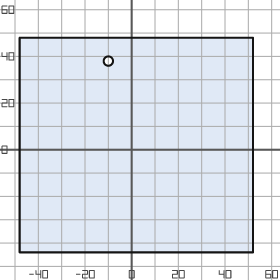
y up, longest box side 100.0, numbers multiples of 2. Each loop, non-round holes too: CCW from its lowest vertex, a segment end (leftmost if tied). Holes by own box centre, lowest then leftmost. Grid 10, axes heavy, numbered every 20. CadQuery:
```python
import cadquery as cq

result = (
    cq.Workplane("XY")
    .moveTo(-48.0, -44.0)
    .lineTo(52.0, -44.0)
    .lineTo(52.0, 48.0)
    .lineTo(-48.0, 48.0)
    .close()
    .moveTo(-10.0, 38.0)
    .circle(2.0)
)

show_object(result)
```